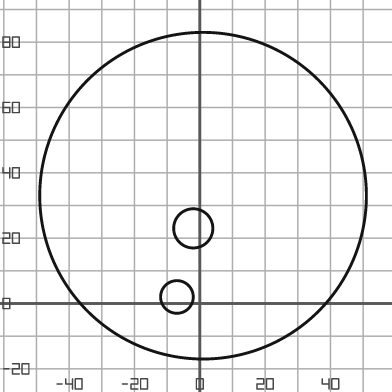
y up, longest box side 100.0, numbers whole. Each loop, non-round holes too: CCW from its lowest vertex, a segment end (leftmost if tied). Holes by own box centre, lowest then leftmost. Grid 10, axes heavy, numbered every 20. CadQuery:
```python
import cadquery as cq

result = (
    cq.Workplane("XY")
    .moveTo(1.0, 33.0)
    .circle(50.0)
    .moveTo(-7.0, 2.0)
    .circle(5.0)
    .moveTo(-2.0, 23.0)
    .circle(6.0)
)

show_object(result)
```